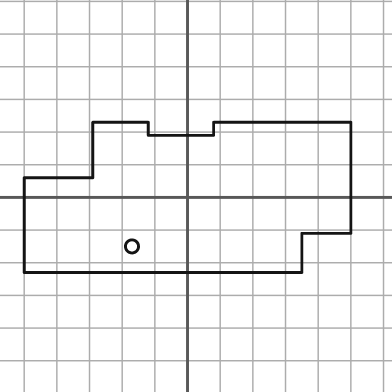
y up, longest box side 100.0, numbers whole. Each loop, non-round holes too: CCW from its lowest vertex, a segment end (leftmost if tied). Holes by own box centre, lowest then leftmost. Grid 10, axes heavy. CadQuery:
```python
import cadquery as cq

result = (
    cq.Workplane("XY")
    .moveTo(-50.0, -23.0)
    .lineTo(35.0, -23.0)
    .lineTo(35.0, -11.0)
    .lineTo(50.0, -11.0)
    .lineTo(50.0, 23.0)
    .lineTo(8.0, 23.0)
    .lineTo(8.0, 19.0)
    .lineTo(-12.0, 19.0)
    .lineTo(-12.0, 23.0)
    .lineTo(-29.0, 23.0)
    .lineTo(-29.0, 6.0)
    .lineTo(-50.0, 6.0)
    .close()
    .moveTo(-17.0, -15.0)
    .circle(2.0)
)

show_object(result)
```